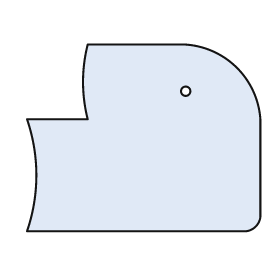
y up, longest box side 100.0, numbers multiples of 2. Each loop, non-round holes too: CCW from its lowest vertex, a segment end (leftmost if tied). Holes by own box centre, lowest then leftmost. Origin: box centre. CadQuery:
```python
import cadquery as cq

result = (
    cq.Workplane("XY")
    .moveTo(-50.0, -40.0)
    .lineTo(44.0, -40.0)
    .threePointArc((48.0, -38.0), (50.0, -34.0))
    .lineTo(50.0, 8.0)
    .threePointArc((40.0, 30.0), (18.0, 40.0))
    .lineTo(-24.0, 40.0)
    .threePointArc((-26.0, 24.0), (-24.0, 8.0))
    .lineTo(-50.0, 8.0)
    .threePointArc((-46.0, -16.0), (-50.0, -40.0))
    .close()
    .moveTo(18.0, 20.0)
    .circle(2.0)
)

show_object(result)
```